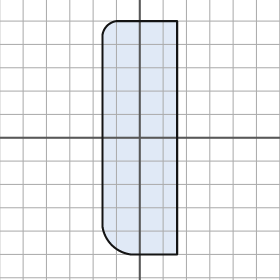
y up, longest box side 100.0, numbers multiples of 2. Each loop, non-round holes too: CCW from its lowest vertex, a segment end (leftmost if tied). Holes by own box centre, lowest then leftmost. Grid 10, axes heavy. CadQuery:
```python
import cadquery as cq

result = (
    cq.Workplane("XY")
    .moveTo(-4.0, -50.0)
    .lineTo(16.0, -50.0)
    .lineTo(16.0, 50.0)
    .lineTo(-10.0, 50.0)
    .threePointArc((-14.0, 48.0), (-16.0, 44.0))
    .lineTo(-16.0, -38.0)
    .threePointArc((-12.0, -46.0), (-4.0, -50.0))
    .close()
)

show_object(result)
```